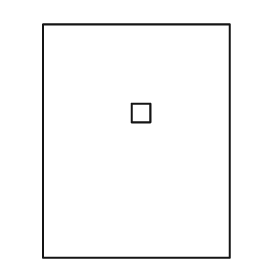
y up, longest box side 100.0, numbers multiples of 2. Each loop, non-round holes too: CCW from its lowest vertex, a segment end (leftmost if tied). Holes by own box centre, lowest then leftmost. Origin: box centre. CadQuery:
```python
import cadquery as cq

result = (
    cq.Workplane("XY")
    .moveTo(-40.0, -50.0)
    .lineTo(40.0, -50.0)
    .lineTo(40.0, 50.0)
    .lineTo(-40.0, 50.0)
    .close()
    .moveTo(-2.0, 8.0)
    .lineTo(6.0, 8.0)
    .lineTo(6.0, 16.0)
    .lineTo(-2.0, 16.0)
    .close()
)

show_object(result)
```